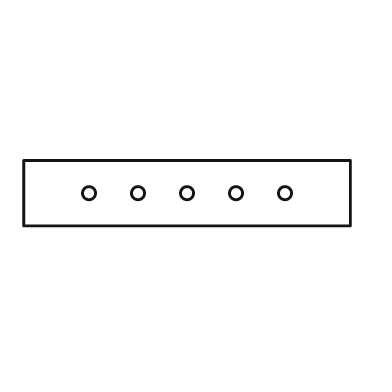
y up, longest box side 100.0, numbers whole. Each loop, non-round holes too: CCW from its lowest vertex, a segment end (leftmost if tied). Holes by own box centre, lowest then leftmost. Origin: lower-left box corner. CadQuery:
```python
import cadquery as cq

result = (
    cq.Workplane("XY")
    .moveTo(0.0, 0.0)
    .lineTo(100.0, 0.0)
    .lineTo(100.0, 20.0)
    .lineTo(0.0, 20.0)
    .close()
    .moveTo(20.0, 10.0)
    .circle(2.0)
    .moveTo(35.0, 10.0)
    .circle(2.0)
    .moveTo(50.0, 10.0)
    .circle(2.0)
    .moveTo(65.0, 10.0)
    .circle(2.0)
    .moveTo(80.0, 10.0)
    .circle(2.0)
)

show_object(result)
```